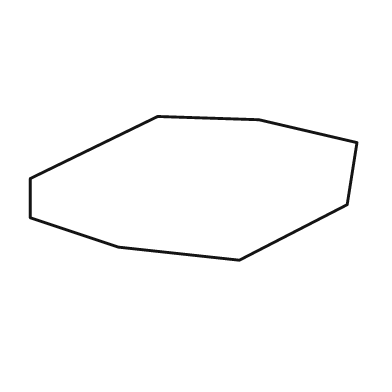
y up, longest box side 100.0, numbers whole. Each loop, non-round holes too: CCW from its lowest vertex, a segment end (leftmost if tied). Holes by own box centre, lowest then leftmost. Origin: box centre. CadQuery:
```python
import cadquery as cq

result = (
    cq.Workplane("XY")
    .moveTo(14.0, -22.0)
    .lineTo(47.0, -5.0)
    .lineTo(50.0, 14.0)
    .lineTo(20.0, 21.0)
    .lineTo(-11.0, 22.0)
    .lineTo(-50.0, 3.0)
    .lineTo(-50.0, -9.0)
    .lineTo(-23.0, -18.0)
    .close()
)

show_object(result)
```